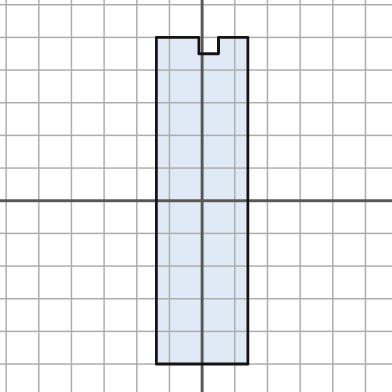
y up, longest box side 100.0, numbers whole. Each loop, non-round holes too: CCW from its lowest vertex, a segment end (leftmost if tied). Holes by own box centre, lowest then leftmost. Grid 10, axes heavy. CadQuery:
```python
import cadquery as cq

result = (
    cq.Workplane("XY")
    .moveTo(-14.0, -50.0)
    .lineTo(14.0, -50.0)
    .lineTo(14.0, 50.0)
    .lineTo(5.0, 50.0)
    .lineTo(5.0, 45.0)
    .lineTo(-1.0, 45.0)
    .lineTo(-1.0, 50.0)
    .lineTo(-14.0, 50.0)
    .close()
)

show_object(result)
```